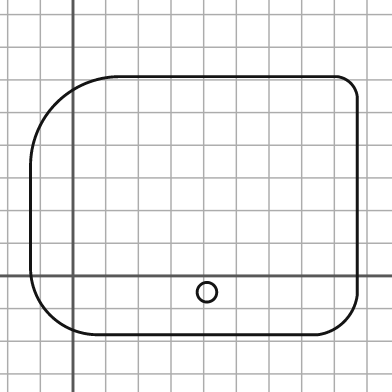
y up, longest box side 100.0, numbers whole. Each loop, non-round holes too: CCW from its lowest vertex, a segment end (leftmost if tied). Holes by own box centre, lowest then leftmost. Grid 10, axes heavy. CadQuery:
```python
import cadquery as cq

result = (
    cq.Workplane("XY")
    .moveTo(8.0, -18.0)
    .lineTo(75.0, -18.0)
    .threePointArc((83.0, -14.0), (87.0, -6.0))
    .lineTo(87.0, 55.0)
    .threePointArc((85.0, 59.0), (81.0, 61.0))
    .lineTo(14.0, 61.0)
    .threePointArc((-5.0, 53.0), (-13.0, 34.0))
    .lineTo(-13.0, 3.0)
    .threePointArc((-7.0, -12.0), (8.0, -18.0))
    .close()
    .moveTo(41.0, -5.0)
    .circle(3.0)
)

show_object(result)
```